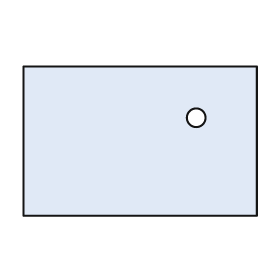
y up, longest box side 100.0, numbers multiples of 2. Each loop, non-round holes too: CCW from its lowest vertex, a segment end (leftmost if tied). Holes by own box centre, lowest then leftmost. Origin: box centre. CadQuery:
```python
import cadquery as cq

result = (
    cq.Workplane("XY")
    .moveTo(-50.0, -32.0)
    .lineTo(50.0, -32.0)
    .lineTo(50.0, 32.0)
    .lineTo(-50.0, 32.0)
    .close()
    .moveTo(24.0, 10.0)
    .circle(4.0)
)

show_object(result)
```